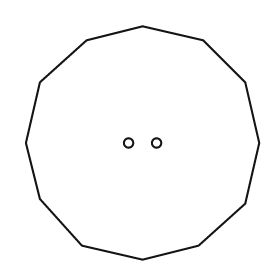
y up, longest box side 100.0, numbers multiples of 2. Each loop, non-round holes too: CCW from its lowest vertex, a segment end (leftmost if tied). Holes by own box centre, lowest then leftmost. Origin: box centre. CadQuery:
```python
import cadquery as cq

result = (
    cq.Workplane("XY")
    .moveTo(0.0, -50.0)
    .lineTo(24.0, -44.0)
    .lineTo(44.0, -26.0)
    .lineTo(50.0, 0.0)
    .lineTo(44.0, 26.0)
    .lineTo(26.0, 44.0)
    .lineTo(0.0, 50.0)
    .lineTo(-24.0, 44.0)
    .lineTo(-44.0, 26.0)
    .lineTo(-50.0, 0.0)
    .lineTo(-44.0, -24.0)
    .lineTo(-26.0, -44.0)
    .close()
    .moveTo(-6.0, 0.0)
    .circle(2.0)
    .moveTo(6.0, 0.0)
    .circle(2.0)
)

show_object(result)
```